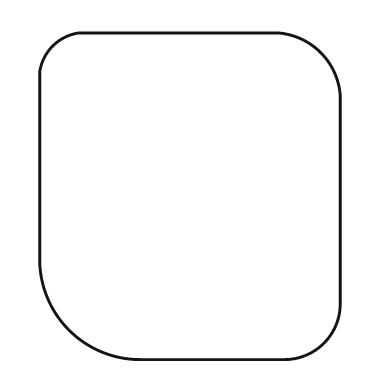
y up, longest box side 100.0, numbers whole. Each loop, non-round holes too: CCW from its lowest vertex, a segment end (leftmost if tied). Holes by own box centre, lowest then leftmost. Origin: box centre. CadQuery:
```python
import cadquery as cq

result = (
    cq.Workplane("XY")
    .moveTo(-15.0, -50.0)
    .lineTo(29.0, -50.0)
    .threePointArc((41.0, -45.0), (46.0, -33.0))
    .lineTo(46.0, 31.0)
    .threePointArc((40.0, 44.0), (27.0, 50.0))
    .lineTo(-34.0, 50.0)
    .threePointArc((-42.0, 46.0), (-46.0, 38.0))
    .lineTo(-46.0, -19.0)
    .threePointArc((-37.0, -41.0), (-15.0, -50.0))
    .close()
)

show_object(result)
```